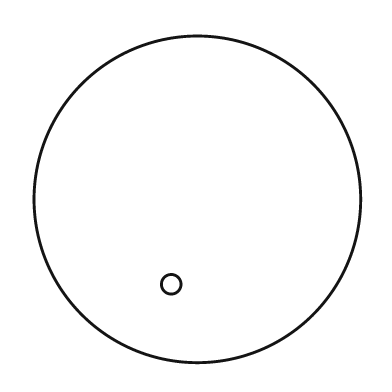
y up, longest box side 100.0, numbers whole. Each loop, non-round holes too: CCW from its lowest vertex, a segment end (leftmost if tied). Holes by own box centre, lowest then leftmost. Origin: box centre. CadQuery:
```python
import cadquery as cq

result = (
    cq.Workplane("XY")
    .moveTo(0.0, 0.0)
    .circle(50.0)
    .moveTo(-8.0, -26.0)
    .circle(3.0)
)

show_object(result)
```